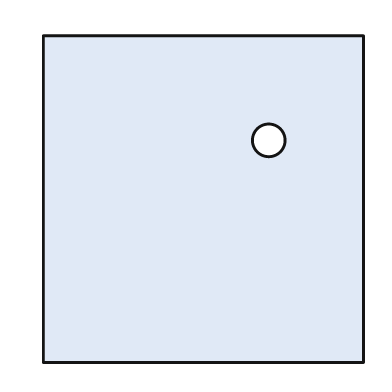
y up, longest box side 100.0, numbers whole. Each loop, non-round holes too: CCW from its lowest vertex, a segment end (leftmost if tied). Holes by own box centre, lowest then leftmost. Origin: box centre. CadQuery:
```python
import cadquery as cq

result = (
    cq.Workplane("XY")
    .moveTo(-49.0, -50.0)
    .lineTo(49.0, -50.0)
    .lineTo(49.0, 50.0)
    .lineTo(-49.0, 50.0)
    .close()
    .moveTo(20.0, 18.0)
    .circle(5.0)
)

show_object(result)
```